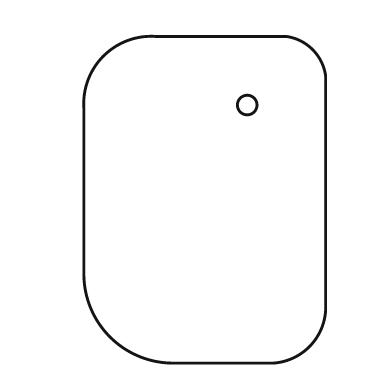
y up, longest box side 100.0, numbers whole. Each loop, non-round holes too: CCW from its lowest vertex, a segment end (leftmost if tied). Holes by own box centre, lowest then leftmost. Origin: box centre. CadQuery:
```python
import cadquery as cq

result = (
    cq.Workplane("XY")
    .moveTo(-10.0, -50.0)
    .lineTo(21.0, -50.0)
    .threePointArc((32.0, -45.0), (37.0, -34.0))
    .lineTo(37.0, 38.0)
    .threePointArc((33.0, 46.0), (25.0, 50.0))
    .lineTo(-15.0, 50.0)
    .threePointArc((-31.0, 44.0), (-37.0, 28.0))
    .lineTo(-37.0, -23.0)
    .threePointArc((-29.0, -42.0), (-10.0, -50.0))
    .close()
    .moveTo(13.0, 29.0)
    .circle(3.0)
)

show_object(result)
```